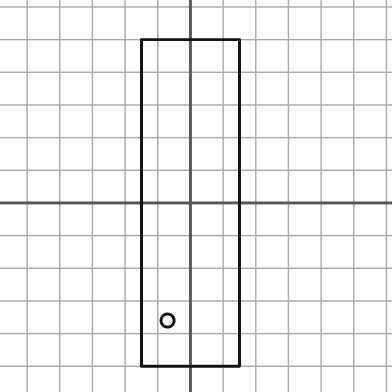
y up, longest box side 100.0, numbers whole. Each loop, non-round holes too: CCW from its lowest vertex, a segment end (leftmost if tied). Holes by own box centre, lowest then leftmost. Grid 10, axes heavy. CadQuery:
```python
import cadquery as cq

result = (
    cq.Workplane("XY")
    .moveTo(-15.0, -50.0)
    .lineTo(15.0, -50.0)
    .lineTo(15.0, 50.0)
    .lineTo(-15.0, 50.0)
    .close()
    .moveTo(-7.0, -36.0)
    .circle(2.0)
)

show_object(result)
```